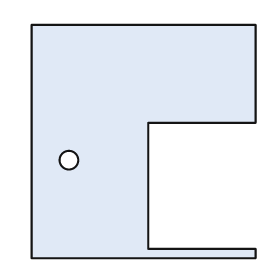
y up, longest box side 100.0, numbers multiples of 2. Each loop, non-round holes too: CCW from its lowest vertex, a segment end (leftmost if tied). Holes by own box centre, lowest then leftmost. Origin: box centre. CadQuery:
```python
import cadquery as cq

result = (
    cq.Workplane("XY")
    .moveTo(-48.0, -50.0)
    .lineTo(48.0, -50.0)
    .lineTo(48.0, -46.0)
    .lineTo(2.0, -46.0)
    .lineTo(2.0, 8.0)
    .lineTo(48.0, 8.0)
    .lineTo(48.0, 50.0)
    .lineTo(-48.0, 50.0)
    .close()
    .moveTo(-32.0, -8.0)
    .circle(4.0)
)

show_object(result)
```